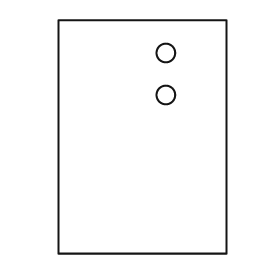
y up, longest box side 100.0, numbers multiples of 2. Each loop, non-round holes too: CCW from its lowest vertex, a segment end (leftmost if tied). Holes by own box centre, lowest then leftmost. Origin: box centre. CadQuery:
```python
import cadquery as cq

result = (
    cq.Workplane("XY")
    .moveTo(-36.0, -50.0)
    .lineTo(36.0, -50.0)
    .lineTo(36.0, 50.0)
    .lineTo(-36.0, 50.0)
    .close()
    .moveTo(10.0, 18.0)
    .circle(4.0)
    .moveTo(10.0, 36.0)
    .circle(4.0)
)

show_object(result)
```